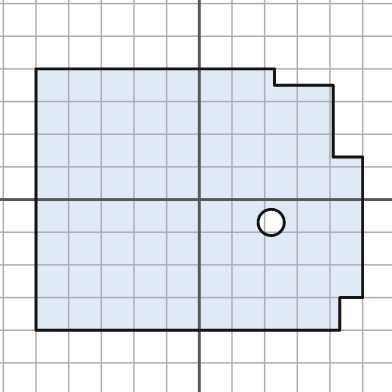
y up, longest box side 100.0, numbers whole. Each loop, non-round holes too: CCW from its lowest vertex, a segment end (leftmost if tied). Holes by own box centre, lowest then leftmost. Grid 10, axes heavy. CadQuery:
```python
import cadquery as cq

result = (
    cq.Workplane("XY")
    .moveTo(-50.0, -40.0)
    .lineTo(43.0, -40.0)
    .lineTo(43.0, -30.0)
    .lineTo(50.0, -30.0)
    .lineTo(50.0, 13.0)
    .lineTo(41.0, 13.0)
    .lineTo(41.0, 35.0)
    .lineTo(23.0, 35.0)
    .lineTo(23.0, 40.0)
    .lineTo(-50.0, 40.0)
    .close()
    .moveTo(22.0, -7.0)
    .circle(4.0)
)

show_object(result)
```